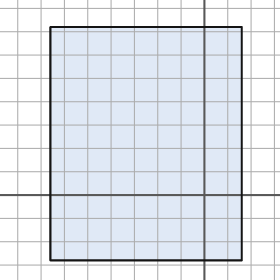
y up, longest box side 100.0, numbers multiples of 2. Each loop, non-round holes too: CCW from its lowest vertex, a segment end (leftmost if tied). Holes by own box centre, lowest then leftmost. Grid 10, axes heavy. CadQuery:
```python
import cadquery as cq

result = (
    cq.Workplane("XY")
    .moveTo(-66.0, -28.0)
    .lineTo(16.0, -28.0)
    .lineTo(16.0, 72.0)
    .lineTo(-66.0, 72.0)
    .close()
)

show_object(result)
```